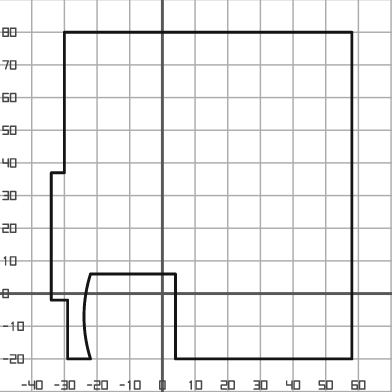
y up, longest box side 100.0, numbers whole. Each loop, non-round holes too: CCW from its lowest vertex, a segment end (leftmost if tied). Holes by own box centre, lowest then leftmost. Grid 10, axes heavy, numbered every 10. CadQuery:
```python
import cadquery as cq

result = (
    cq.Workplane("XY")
    .moveTo(-29.0, -20.0)
    .lineTo(-22.0, -20.0)
    .threePointArc((-24.0, -7.0), (-22.0, 6.0))
    .lineTo(4.0, 6.0)
    .lineTo(4.0, -20.0)
    .lineTo(58.0, -20.0)
    .lineTo(58.0, 80.0)
    .lineTo(-30.0, 80.0)
    .lineTo(-30.0, 37.0)
    .lineTo(-34.0, 37.0)
    .lineTo(-34.0, -2.0)
    .lineTo(-29.0, -2.0)
    .close()
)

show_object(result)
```